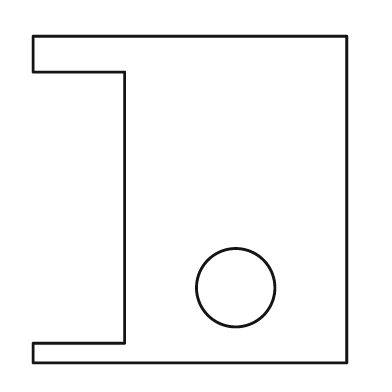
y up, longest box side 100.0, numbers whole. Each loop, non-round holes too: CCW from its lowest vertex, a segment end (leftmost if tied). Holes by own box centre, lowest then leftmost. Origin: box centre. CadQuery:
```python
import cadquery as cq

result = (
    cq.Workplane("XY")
    .moveTo(-48.0, -50.0)
    .lineTo(48.0, -50.0)
    .lineTo(48.0, 50.0)
    .lineTo(-48.0, 50.0)
    .lineTo(-48.0, 39.0)
    .lineTo(-20.0, 39.0)
    .lineTo(-20.0, -44.0)
    .lineTo(-48.0, -44.0)
    .close()
    .moveTo(14.0, -27.0)
    .circle(12.0)
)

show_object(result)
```